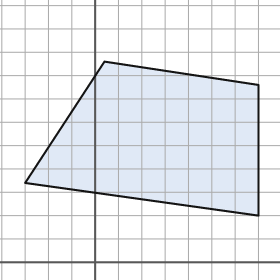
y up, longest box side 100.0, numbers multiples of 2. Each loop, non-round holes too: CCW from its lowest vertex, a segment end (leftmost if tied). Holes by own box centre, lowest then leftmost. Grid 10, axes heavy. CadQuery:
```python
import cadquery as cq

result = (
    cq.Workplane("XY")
    .moveTo(70.0, 20.0)
    .lineTo(70.0, 76.0)
    .lineTo(4.0, 86.0)
    .lineTo(-30.0, 34.0)
    .close()
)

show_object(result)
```